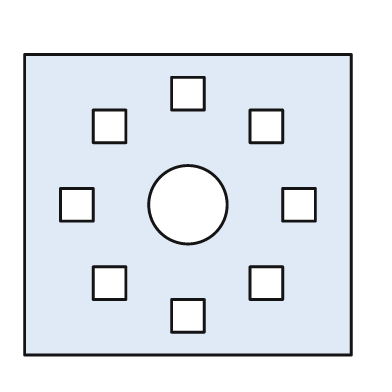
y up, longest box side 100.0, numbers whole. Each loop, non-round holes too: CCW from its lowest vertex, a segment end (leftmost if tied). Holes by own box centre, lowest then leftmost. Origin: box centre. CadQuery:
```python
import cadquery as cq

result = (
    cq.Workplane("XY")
    .moveTo(-50.0, -46.0)
    .lineTo(50.0, -46.0)
    .lineTo(50.0, 46.0)
    .lineTo(-50.0, 46.0)
    .close()
    .moveTo(-5.0, -39.0)
    .lineTo(5.0, -39.0)
    .lineTo(5.0, -29.0)
    .lineTo(-5.0, -29.0)
    .close()
    .moveTo(-29.0, -29.0)
    .lineTo(-19.0, -29.0)
    .lineTo(-19.0, -19.0)
    .lineTo(-29.0, -19.0)
    .close()
    .moveTo(19.0, -29.0)
    .lineTo(29.0, -29.0)
    .lineTo(29.0, -19.0)
    .lineTo(19.0, -19.0)
    .close()
    .moveTo(-39.0, -5.0)
    .lineTo(-29.0, -5.0)
    .lineTo(-29.0, 5.0)
    .lineTo(-39.0, 5.0)
    .close()
    .moveTo(0.0, 0.0)
    .circle(12.0)
    .moveTo(29.0, -5.0)
    .lineTo(39.0, -5.0)
    .lineTo(39.0, 5.0)
    .lineTo(29.0, 5.0)
    .close()
    .moveTo(-29.0, 19.0)
    .lineTo(-19.0, 19.0)
    .lineTo(-19.0, 29.0)
    .lineTo(-29.0, 29.0)
    .close()
    .moveTo(19.0, 19.0)
    .lineTo(29.0, 19.0)
    .lineTo(29.0, 29.0)
    .lineTo(19.0, 29.0)
    .close()
    .moveTo(-5.0, 29.0)
    .lineTo(5.0, 29.0)
    .lineTo(5.0, 39.0)
    .lineTo(-5.0, 39.0)
    .close()
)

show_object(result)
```